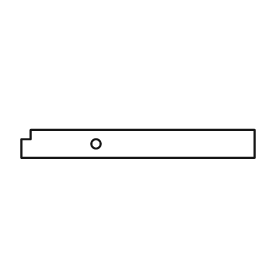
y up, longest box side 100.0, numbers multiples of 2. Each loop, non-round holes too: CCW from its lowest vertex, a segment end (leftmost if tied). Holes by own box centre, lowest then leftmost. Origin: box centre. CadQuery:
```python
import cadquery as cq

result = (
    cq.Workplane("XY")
    .moveTo(-50.0, -6.0)
    .lineTo(50.0, -6.0)
    .lineTo(50.0, 6.0)
    .lineTo(-46.0, 6.0)
    .lineTo(-46.0, 2.0)
    .lineTo(-50.0, 2.0)
    .close()
    .moveTo(-18.0, 0.0)
    .circle(2.0)
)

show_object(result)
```